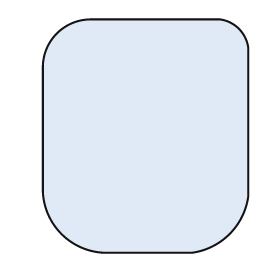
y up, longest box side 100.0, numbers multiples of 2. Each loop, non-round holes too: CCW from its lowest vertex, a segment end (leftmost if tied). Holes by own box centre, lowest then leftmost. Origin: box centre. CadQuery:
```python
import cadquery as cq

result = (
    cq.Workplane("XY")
    .moveTo(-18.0, -50.0)
    .lineTo(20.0, -50.0)
    .threePointArc((36.0, -42.0), (44.0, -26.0))
    .lineTo(44.0, 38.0)
    .threePointArc((40.0, 46.0), (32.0, 50.0))
    .lineTo(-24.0, 50.0)
    .threePointArc((-38.0, 44.0), (-44.0, 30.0))
    .lineTo(-44.0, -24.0)
    .threePointArc((-36.0, -42.0), (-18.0, -50.0))
    .close()
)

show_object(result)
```